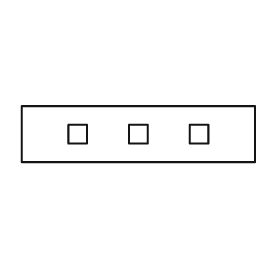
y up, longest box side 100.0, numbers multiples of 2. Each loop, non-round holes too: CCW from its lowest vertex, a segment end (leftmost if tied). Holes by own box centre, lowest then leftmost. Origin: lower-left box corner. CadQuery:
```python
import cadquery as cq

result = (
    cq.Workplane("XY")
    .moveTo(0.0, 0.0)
    .lineTo(100.0, 0.0)
    .lineTo(100.0, 24.0)
    .lineTo(0.0, 24.0)
    .close()
    .moveTo(20.0, 8.0)
    .lineTo(28.0, 8.0)
    .lineTo(28.0, 16.0)
    .lineTo(20.0, 16.0)
    .close()
    .moveTo(46.0, 8.0)
    .lineTo(54.0, 8.0)
    .lineTo(54.0, 16.0)
    .lineTo(46.0, 16.0)
    .close()
    .moveTo(72.0, 8.0)
    .lineTo(80.0, 8.0)
    .lineTo(80.0, 16.0)
    .lineTo(72.0, 16.0)
    .close()
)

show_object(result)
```